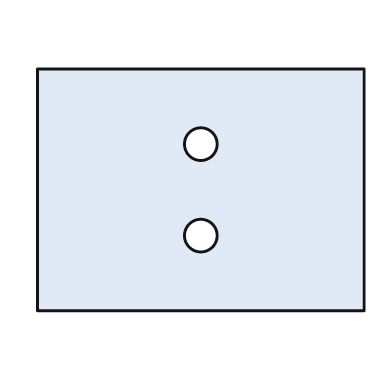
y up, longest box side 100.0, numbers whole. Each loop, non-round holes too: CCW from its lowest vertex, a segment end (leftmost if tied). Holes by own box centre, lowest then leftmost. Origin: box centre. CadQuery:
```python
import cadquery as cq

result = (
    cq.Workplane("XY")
    .moveTo(-50.0, -37.0)
    .lineTo(50.0, -37.0)
    .lineTo(50.0, 37.0)
    .lineTo(-50.0, 37.0)
    .close()
    .moveTo(0.0, -14.0)
    .circle(5.0)
    .moveTo(0.0, 14.0)
    .circle(5.0)
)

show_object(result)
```